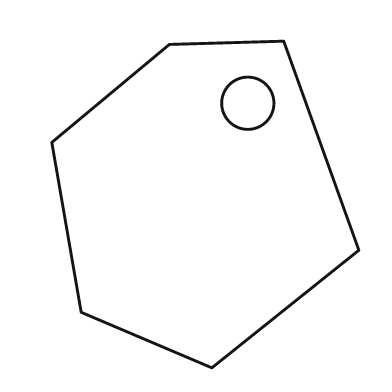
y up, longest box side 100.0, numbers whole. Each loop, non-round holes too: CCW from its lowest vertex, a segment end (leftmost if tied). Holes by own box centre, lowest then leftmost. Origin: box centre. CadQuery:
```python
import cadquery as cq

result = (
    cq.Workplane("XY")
    .moveTo(2.0, -50.0)
    .lineTo(47.0, -14.0)
    .lineTo(24.0, 50.0)
    .lineTo(-11.0, 49.0)
    .lineTo(-47.0, 19.0)
    .lineTo(-38.0, -33.0)
    .close()
    .moveTo(13.0, 31.0)
    .circle(8.0)
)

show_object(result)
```